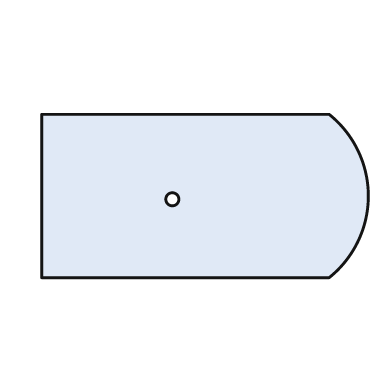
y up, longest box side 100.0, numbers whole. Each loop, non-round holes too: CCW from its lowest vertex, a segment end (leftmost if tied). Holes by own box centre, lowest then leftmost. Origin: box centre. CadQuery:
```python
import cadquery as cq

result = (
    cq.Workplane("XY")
    .moveTo(-50.0, -25.0)
    .lineTo(38.0, -25.0)
    .threePointArc((50.0, 0.0), (38.0, 25.0))
    .lineTo(-50.0, 25.0)
    .close()
    .moveTo(-10.0, -1.0)
    .circle(2.0)
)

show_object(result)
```